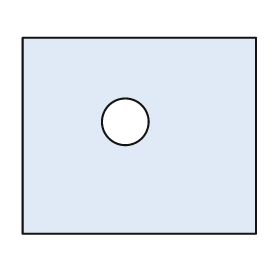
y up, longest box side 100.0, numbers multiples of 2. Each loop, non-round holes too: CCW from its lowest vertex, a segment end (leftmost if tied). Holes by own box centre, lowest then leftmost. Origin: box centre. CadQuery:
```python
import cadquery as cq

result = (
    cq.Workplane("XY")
    .moveTo(-50.0, -42.0)
    .lineTo(50.0, -42.0)
    .lineTo(50.0, 42.0)
    .lineTo(-50.0, 42.0)
    .close()
    .moveTo(-6.0, 6.0)
    .circle(10.0)
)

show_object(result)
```